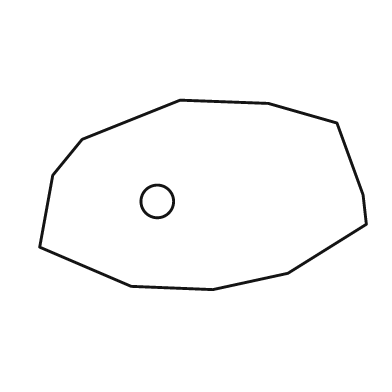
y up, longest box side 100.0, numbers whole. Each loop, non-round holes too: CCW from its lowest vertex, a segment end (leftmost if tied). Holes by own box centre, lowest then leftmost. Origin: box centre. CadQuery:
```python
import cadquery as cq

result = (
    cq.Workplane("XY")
    .moveTo(3.0, -29.0)
    .lineTo(26.0, -24.0)
    .lineTo(50.0, -9.0)
    .lineTo(49.0, 0.0)
    .lineTo(41.0, 22.0)
    .lineTo(20.0, 28.0)
    .lineTo(-7.0, 29.0)
    .lineTo(-37.0, 17.0)
    .lineTo(-46.0, 6.0)
    .lineTo(-50.0, -16.0)
    .lineTo(-22.0, -28.0)
    .close()
    .moveTo(-14.0, -2.0)
    .circle(5.0)
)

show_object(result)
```